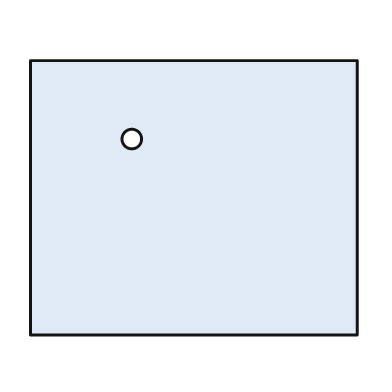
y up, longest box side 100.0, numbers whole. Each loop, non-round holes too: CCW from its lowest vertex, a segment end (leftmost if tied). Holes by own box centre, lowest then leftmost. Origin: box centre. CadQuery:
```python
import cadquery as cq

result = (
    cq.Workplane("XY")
    .moveTo(-50.0, -42.0)
    .lineTo(50.0, -42.0)
    .lineTo(50.0, 42.0)
    .lineTo(-50.0, 42.0)
    .close()
    .moveTo(-19.0, 18.0)
    .circle(3.0)
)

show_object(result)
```